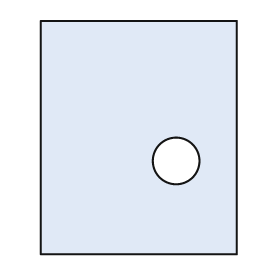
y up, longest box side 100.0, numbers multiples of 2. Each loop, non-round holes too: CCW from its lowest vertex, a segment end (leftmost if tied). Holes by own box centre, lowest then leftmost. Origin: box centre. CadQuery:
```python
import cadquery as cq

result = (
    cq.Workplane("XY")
    .moveTo(-42.0, -50.0)
    .lineTo(42.0, -50.0)
    .lineTo(42.0, 50.0)
    .lineTo(-42.0, 50.0)
    .close()
    .moveTo(16.0, -10.0)
    .circle(10.0)
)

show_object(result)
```